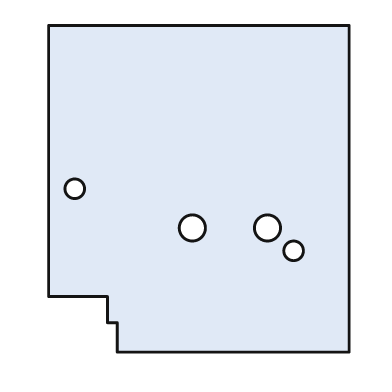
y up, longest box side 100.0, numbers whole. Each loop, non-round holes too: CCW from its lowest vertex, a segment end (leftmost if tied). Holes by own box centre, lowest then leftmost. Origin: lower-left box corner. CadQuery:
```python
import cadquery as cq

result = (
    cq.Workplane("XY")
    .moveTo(21.0, 0.0)
    .lineTo(92.0, 0.0)
    .lineTo(92.0, 100.0)
    .lineTo(0.0, 100.0)
    .lineTo(0.0, 17.0)
    .lineTo(18.0, 17.0)
    .lineTo(18.0, 9.0)
    .lineTo(21.0, 9.0)
    .close()
    .moveTo(75.0, 31.0)
    .circle(3.0)
    .moveTo(44.0, 38.0)
    .circle(4.0)
    .moveTo(67.0, 38.0)
    .circle(4.0)
    .moveTo(8.0, 50.0)
    .circle(3.0)
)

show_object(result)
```